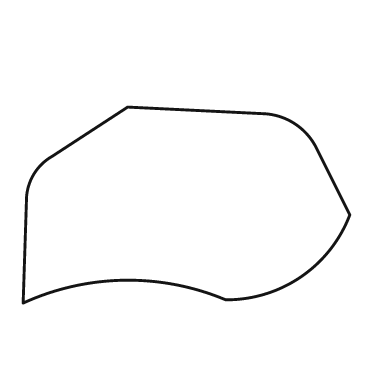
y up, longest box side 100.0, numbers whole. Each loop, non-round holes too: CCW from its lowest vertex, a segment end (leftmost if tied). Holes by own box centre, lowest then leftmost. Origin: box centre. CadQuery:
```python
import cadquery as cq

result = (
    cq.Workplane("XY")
    .moveTo(-50.0, -30.0)
    .threePointArc((-19.0, -23.0), (12.0, -29.0))
    .threePointArc((35.0, -22.0), (50.0, -3.0))
    .lineTo(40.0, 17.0)
    .threePointArc((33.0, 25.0), (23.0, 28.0))
    .lineTo(-18.0, 30.0)
    .lineTo(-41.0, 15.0)
    .threePointArc((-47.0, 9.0), (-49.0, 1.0))
    .close()
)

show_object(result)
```